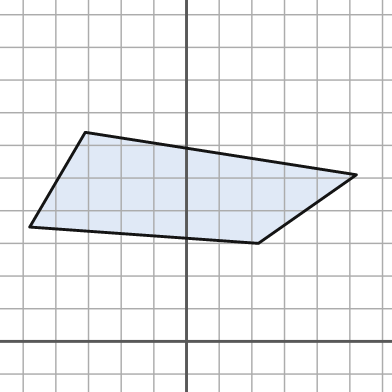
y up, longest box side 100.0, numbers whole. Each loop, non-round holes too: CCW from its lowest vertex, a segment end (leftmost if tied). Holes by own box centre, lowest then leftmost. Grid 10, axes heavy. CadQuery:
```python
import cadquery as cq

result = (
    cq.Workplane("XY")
    .moveTo(22.0, 30.0)
    .lineTo(52.0, 51.0)
    .lineTo(-31.0, 64.0)
    .lineTo(-48.0, 35.0)
    .close()
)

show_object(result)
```